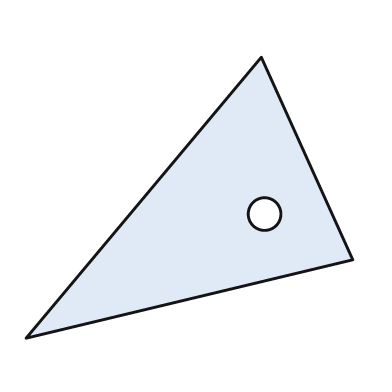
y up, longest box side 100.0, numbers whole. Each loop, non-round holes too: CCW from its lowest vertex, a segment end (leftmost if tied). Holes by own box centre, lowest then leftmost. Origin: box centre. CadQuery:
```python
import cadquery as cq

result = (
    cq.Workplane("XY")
    .moveTo(-50.0, -43.0)
    .lineTo(50.0, -19.0)
    .lineTo(22.0, 43.0)
    .close()
    .moveTo(23.0, -5.0)
    .circle(5.0)
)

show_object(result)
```